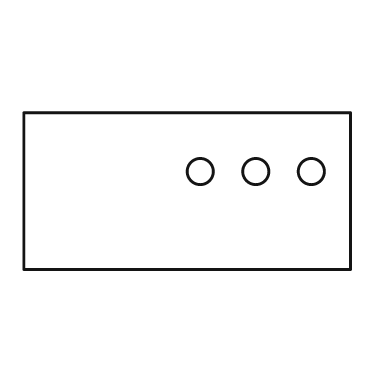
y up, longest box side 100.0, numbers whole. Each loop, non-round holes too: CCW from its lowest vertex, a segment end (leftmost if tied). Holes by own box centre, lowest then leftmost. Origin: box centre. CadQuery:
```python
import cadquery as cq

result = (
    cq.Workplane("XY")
    .moveTo(-50.0, -24.0)
    .lineTo(50.0, -24.0)
    .lineTo(50.0, 24.0)
    .lineTo(-50.0, 24.0)
    .close()
    .moveTo(4.0, 6.0)
    .circle(4.0)
    .moveTo(21.0, 6.0)
    .circle(4.0)
    .moveTo(38.0, 6.0)
    .circle(4.0)
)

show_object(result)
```